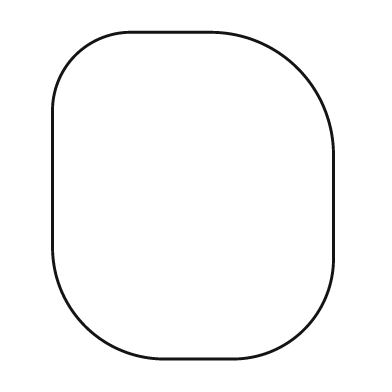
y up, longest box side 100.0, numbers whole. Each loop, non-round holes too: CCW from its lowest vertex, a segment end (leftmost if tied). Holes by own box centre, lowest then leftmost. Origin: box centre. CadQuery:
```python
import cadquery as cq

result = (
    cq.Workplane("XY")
    .moveTo(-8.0, -50.0)
    .lineTo(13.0, -50.0)
    .threePointArc((34.0, -41.0), (43.0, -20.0))
    .lineTo(43.0, 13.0)
    .threePointArc((32.0, 39.0), (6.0, 50.0))
    .lineTo(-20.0, 50.0)
    .threePointArc((-36.0, 43.0), (-43.0, 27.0))
    .lineTo(-43.0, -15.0)
    .threePointArc((-33.0, -40.0), (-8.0, -50.0))
    .close()
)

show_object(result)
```